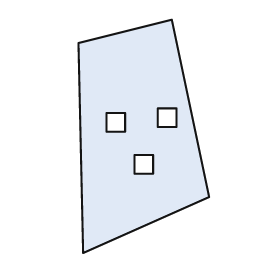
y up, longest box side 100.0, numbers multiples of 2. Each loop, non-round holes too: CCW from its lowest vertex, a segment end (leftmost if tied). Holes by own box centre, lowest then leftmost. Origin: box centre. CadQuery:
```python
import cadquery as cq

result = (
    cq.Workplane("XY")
    .moveTo(-26.0, -50.0)
    .lineTo(28.0, -26.0)
    .lineTo(12.0, 50.0)
    .lineTo(-28.0, 40.0)
    .close()
    .moveTo(-4.0, -16.0)
    .lineTo(4.0, -16.0)
    .lineTo(4.0, -8.0)
    .lineTo(-4.0, -8.0)
    .close()
    .moveTo(-16.0, 2.0)
    .lineTo(-8.0, 2.0)
    .lineTo(-8.0, 10.0)
    .lineTo(-16.0, 10.0)
    .close()
    .moveTo(6.0, 4.0)
    .lineTo(14.0, 4.0)
    .lineTo(14.0, 12.0)
    .lineTo(6.0, 12.0)
    .close()
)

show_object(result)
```